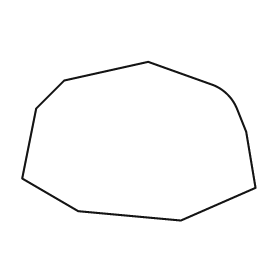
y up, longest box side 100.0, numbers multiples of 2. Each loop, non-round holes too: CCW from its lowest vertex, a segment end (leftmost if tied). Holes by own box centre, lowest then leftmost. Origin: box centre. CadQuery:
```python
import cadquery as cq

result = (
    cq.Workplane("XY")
    .moveTo(18.0, -34.0)
    .lineTo(50.0, -20.0)
    .lineTo(46.0, 4.0)
    .lineTo(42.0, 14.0)
    .threePointArc((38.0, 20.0), (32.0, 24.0))
    .lineTo(4.0, 34.0)
    .lineTo(-32.0, 26.0)
    .lineTo(-44.0, 14.0)
    .lineTo(-50.0, -16.0)
    .lineTo(-26.0, -30.0)
    .close()
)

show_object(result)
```